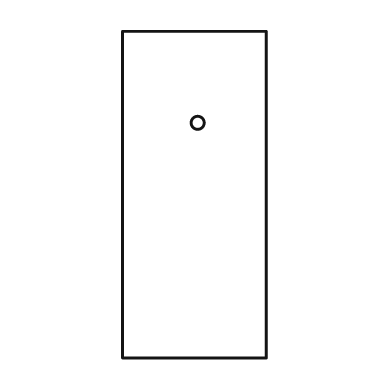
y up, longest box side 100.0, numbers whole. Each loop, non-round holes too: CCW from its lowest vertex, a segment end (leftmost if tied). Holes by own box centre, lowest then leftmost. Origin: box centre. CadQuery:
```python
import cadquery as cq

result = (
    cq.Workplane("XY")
    .moveTo(-22.0, -50.0)
    .lineTo(22.0, -50.0)
    .lineTo(22.0, 50.0)
    .lineTo(-22.0, 50.0)
    .close()
    .moveTo(1.0, 22.0)
    .circle(2.0)
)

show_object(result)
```